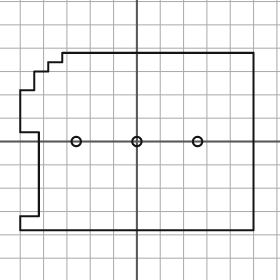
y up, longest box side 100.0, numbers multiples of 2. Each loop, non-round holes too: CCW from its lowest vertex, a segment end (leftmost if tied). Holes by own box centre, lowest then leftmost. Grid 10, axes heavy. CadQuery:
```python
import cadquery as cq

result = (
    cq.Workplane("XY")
    .moveTo(-50.0, -38.0)
    .lineTo(50.0, -38.0)
    .lineTo(50.0, 38.0)
    .lineTo(-32.0, 38.0)
    .lineTo(-32.0, 34.0)
    .lineTo(-38.0, 34.0)
    .lineTo(-38.0, 30.0)
    .lineTo(-44.0, 30.0)
    .lineTo(-44.0, 22.0)
    .lineTo(-50.0, 22.0)
    .lineTo(-50.0, 4.0)
    .lineTo(-42.0, 4.0)
    .lineTo(-42.0, -32.0)
    .lineTo(-50.0, -32.0)
    .close()
    .moveTo(-26.0, 0.0)
    .circle(2.0)
    .moveTo(0.0, 0.0)
    .circle(2.0)
    .moveTo(26.0, 0.0)
    .circle(2.0)
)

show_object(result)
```